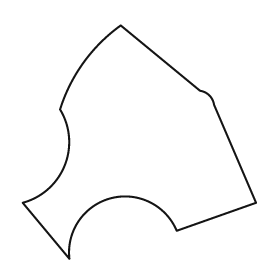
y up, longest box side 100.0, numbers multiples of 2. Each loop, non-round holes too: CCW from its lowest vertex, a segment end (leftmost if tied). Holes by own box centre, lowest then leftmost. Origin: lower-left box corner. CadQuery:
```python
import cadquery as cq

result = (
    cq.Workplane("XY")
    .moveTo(20.0, 0.0)
    .threePointArc((38.0, 26.0), (66.0, 12.0))
    .lineTo(100.0, 24.0)
    .lineTo(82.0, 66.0)
    .threePointArc((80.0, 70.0), (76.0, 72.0))
    .lineTo(42.0, 100.0)
    .threePointArc((26.0, 84.0), (16.0, 64.0))
    .threePointArc((18.0, 40.0), (0.0, 24.0))
    .close()
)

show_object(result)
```